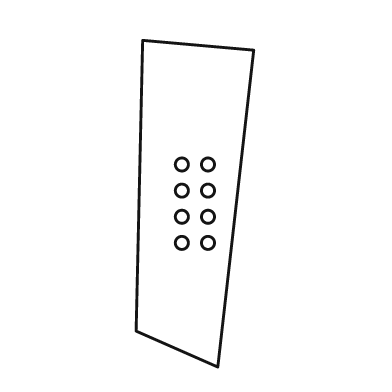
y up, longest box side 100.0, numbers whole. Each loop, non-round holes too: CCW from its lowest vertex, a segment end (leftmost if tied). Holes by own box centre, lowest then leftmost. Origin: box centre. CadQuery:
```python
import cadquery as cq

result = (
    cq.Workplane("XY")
    .moveTo(7.0, -50.0)
    .lineTo(18.0, 47.0)
    .lineTo(-16.0, 50.0)
    .lineTo(-18.0, -39.0)
    .close()
    .moveTo(-4.0, -12.0)
    .circle(2.0)
    .moveTo(4.0, -12.0)
    .circle(2.0)
    .moveTo(-4.0, -4.0)
    .circle(2.0)
    .moveTo(4.0, -4.0)
    .circle(2.0)
    .moveTo(-4.0, 4.0)
    .circle(2.0)
    .moveTo(4.0, 4.0)
    .circle(2.0)
    .moveTo(-4.0, 12.0)
    .circle(2.0)
    .moveTo(4.0, 12.0)
    .circle(2.0)
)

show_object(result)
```